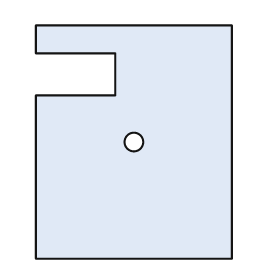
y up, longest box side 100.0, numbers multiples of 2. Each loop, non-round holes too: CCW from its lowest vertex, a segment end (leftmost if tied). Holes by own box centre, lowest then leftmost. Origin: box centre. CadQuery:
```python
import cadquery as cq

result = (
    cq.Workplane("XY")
    .moveTo(-42.0, -50.0)
    .lineTo(42.0, -50.0)
    .lineTo(42.0, 50.0)
    .lineTo(-42.0, 50.0)
    .lineTo(-42.0, 38.0)
    .lineTo(-8.0, 38.0)
    .lineTo(-8.0, 20.0)
    .lineTo(-42.0, 20.0)
    .close()
    .moveTo(0.0, 0.0)
    .circle(4.0)
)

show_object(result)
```